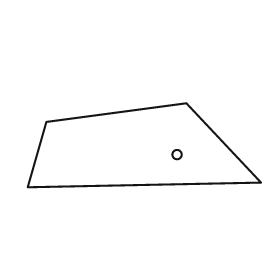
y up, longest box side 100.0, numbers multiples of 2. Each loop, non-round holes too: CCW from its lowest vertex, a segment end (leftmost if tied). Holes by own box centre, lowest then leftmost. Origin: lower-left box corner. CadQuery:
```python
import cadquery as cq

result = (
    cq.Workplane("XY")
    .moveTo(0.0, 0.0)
    .lineTo(100.0, 2.0)
    .lineTo(68.0, 36.0)
    .lineTo(8.0, 28.0)
    .close()
    .moveTo(64.0, 14.0)
    .circle(2.0)
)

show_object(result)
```